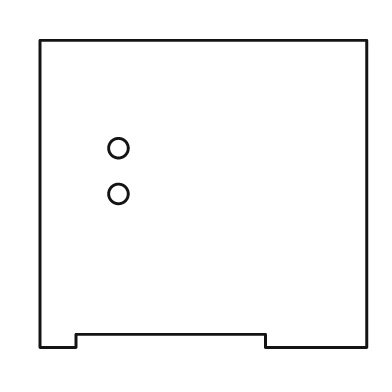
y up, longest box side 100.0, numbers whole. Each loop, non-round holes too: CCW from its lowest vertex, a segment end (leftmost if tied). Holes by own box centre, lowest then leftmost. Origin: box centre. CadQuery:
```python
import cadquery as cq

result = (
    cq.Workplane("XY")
    .moveTo(-50.0, -47.0)
    .lineTo(-39.0, -47.0)
    .lineTo(-39.0, -43.0)
    .lineTo(19.0, -43.0)
    .lineTo(19.0, -47.0)
    .lineTo(50.0, -47.0)
    .lineTo(50.0, 47.0)
    .lineTo(-50.0, 47.0)
    .close()
    .moveTo(-26.0, 0.0)
    .circle(3.0)
    .moveTo(-26.0, 14.0)
    .circle(3.0)
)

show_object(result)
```